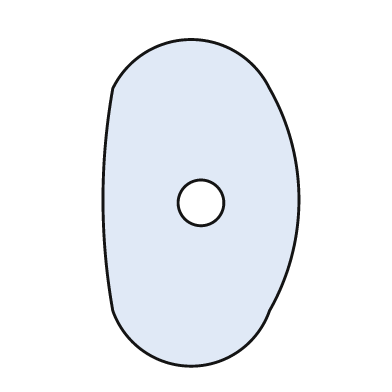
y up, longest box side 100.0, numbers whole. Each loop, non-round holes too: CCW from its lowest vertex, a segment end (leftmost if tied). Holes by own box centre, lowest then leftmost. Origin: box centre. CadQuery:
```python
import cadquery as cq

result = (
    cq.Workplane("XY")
    .moveTo(-27.0, -33.0)
    .threePointArc((-3.0, -50.0), (21.0, -33.0))
    .threePointArc((30.0, 1.0), (21.0, 35.0))
    .threePointArc((-3.0, 50.0), (-27.0, 35.0))
    .threePointArc((-30.0, 1.0), (-27.0, -33.0))
    .close()
    .moveTo(0.0, 0.0)
    .circle(7.0)
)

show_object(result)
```